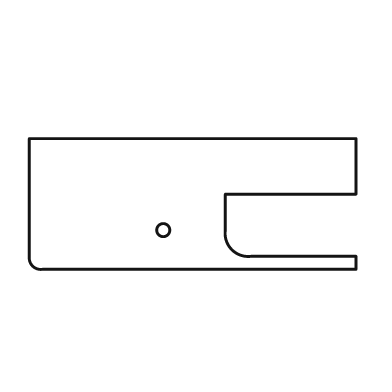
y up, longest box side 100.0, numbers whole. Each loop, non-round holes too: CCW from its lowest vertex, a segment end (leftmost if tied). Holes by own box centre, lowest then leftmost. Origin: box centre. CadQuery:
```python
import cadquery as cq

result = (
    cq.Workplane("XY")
    .moveTo(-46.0, -20.0)
    .lineTo(50.0, -20.0)
    .lineTo(50.0, -16.0)
    .lineTo(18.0, -16.0)
    .threePointArc((12.0, -14.0), (10.0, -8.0))
    .lineTo(10.0, 3.0)
    .lineTo(50.0, 3.0)
    .lineTo(50.0, 20.0)
    .lineTo(-50.0, 20.0)
    .lineTo(-50.0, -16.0)
    .threePointArc((-49.0, -19.0), (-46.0, -20.0))
    .close()
    .moveTo(-9.0, -8.0)
    .circle(2.0)
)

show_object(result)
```